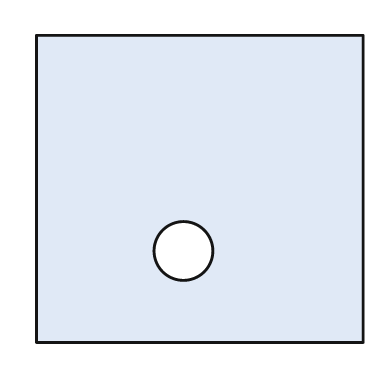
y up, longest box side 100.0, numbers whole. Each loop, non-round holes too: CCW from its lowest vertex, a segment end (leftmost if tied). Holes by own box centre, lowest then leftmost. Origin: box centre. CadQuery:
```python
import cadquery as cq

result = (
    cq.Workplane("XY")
    .moveTo(-50.0, -47.0)
    .lineTo(50.0, -47.0)
    .lineTo(50.0, 47.0)
    .lineTo(-50.0, 47.0)
    .close()
    .moveTo(-5.0, -19.0)
    .circle(9.0)
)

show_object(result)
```